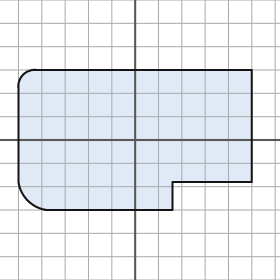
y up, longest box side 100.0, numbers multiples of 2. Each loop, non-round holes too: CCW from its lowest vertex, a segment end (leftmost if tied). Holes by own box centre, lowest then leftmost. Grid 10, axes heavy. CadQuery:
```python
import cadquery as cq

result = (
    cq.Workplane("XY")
    .moveTo(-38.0, -30.0)
    .lineTo(16.0, -30.0)
    .lineTo(16.0, -18.0)
    .lineTo(50.0, -18.0)
    .lineTo(50.0, 30.0)
    .lineTo(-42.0, 30.0)
    .threePointArc((-48.0, 28.0), (-50.0, 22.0))
    .lineTo(-50.0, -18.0)
    .threePointArc((-46.0, -26.0), (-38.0, -30.0))
    .close()
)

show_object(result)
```